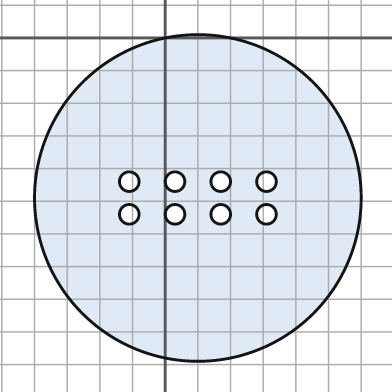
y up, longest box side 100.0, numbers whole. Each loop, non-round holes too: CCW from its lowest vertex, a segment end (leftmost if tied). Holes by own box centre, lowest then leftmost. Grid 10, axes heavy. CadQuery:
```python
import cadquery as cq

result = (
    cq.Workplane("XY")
    .moveTo(10.0, -49.0)
    .circle(50.0)
    .moveTo(-11.0, -54.0)
    .circle(3.0)
    .moveTo(3.0, -54.0)
    .circle(3.0)
    .moveTo(17.0, -54.0)
    .circle(3.0)
    .moveTo(31.0, -54.0)
    .circle(3.0)
    .moveTo(-11.0, -44.0)
    .circle(3.0)
    .moveTo(3.0, -44.0)
    .circle(3.0)
    .moveTo(17.0, -44.0)
    .circle(3.0)
    .moveTo(31.0, -44.0)
    .circle(3.0)
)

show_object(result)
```